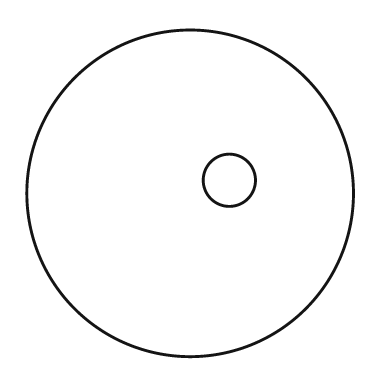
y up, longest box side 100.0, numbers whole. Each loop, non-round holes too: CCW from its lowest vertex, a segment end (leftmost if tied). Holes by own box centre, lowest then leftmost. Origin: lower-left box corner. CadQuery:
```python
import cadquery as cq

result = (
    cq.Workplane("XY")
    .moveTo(50.0, 50.0)
    .circle(50.0)
    .moveTo(62.0, 54.0)
    .circle(8.0)
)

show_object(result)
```